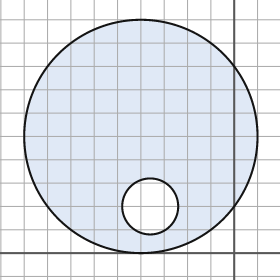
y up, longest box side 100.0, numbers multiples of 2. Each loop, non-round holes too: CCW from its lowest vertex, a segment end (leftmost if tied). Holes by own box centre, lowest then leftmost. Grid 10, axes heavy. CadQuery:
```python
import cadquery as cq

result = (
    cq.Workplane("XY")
    .moveTo(-40.0, 50.0)
    .circle(50.0)
    .moveTo(-36.0, 20.0)
    .circle(12.0)
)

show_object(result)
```